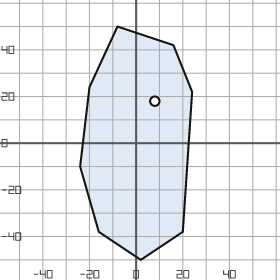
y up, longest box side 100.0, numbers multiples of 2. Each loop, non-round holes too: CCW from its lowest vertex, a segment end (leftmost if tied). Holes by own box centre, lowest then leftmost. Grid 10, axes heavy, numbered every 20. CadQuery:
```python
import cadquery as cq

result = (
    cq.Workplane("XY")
    .moveTo(2.0, -50.0)
    .lineTo(20.0, -38.0)
    .lineTo(24.0, 22.0)
    .lineTo(16.0, 42.0)
    .lineTo(-8.0, 50.0)
    .lineTo(-20.0, 24.0)
    .lineTo(-24.0, -10.0)
    .lineTo(-16.0, -38.0)
    .close()
    .moveTo(8.0, 18.0)
    .circle(2.0)
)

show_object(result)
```